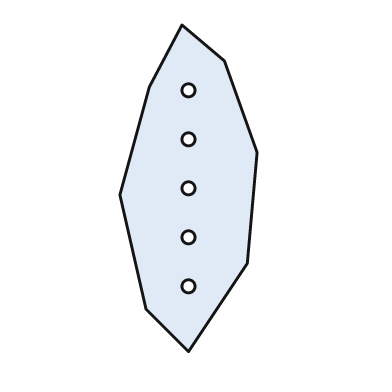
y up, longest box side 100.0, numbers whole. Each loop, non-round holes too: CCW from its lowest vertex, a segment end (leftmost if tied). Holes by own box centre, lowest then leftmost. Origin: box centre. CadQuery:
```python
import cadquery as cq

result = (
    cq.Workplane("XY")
    .moveTo(0.0, -50.0)
    .lineTo(18.0, -23.0)
    .lineTo(21.0, 11.0)
    .lineTo(11.0, 39.0)
    .lineTo(-2.0, 50.0)
    .lineTo(-12.0, 31.0)
    .lineTo(-21.0, -2.0)
    .lineTo(-13.0, -37.0)
    .close()
    .moveTo(0.0, -30.0)
    .circle(2.0)
    .moveTo(0.0, -15.0)
    .circle(2.0)
    .moveTo(0.0, 0.0)
    .circle(2.0)
    .moveTo(0.0, 15.0)
    .circle(2.0)
    .moveTo(0.0, 30.0)
    .circle(2.0)
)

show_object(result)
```